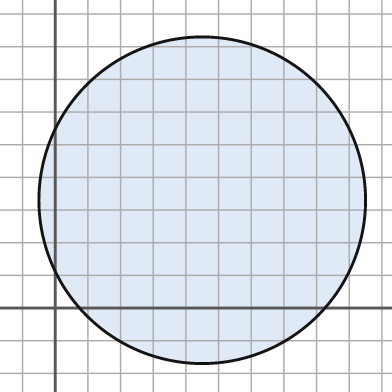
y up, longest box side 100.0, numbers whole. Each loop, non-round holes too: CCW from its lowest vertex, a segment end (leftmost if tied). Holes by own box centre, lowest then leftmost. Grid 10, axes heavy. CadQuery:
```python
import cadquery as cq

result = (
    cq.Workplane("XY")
    .moveTo(45.0, 33.0)
    .circle(50.0)
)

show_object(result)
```